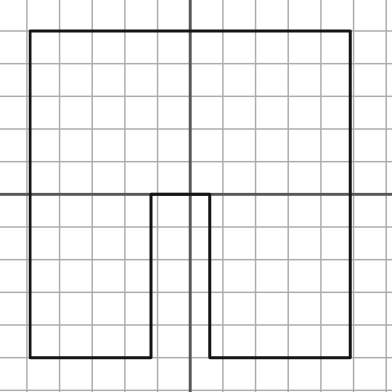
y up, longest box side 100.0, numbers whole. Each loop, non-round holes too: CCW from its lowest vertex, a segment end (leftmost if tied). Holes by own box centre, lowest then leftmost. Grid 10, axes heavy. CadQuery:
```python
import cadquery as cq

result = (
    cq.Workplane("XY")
    .moveTo(-49.0, -50.0)
    .lineTo(-12.0, -50.0)
    .lineTo(-12.0, 0.0)
    .lineTo(6.0, 0.0)
    .lineTo(6.0, -50.0)
    .lineTo(49.0, -50.0)
    .lineTo(49.0, 50.0)
    .lineTo(-49.0, 50.0)
    .close()
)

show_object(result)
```